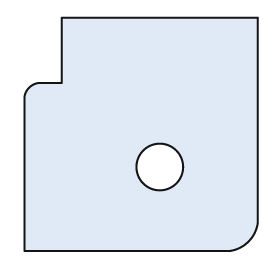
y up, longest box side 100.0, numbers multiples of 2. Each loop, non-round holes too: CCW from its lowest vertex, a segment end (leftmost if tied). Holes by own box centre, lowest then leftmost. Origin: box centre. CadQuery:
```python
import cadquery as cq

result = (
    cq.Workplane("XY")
    .moveTo(-50.0, -50.0)
    .lineTo(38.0, -50.0)
    .threePointArc((46.0, -46.0), (50.0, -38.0))
    .lineTo(50.0, 50.0)
    .lineTo(-34.0, 50.0)
    .lineTo(-34.0, 22.0)
    .lineTo(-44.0, 22.0)
    .threePointArc((-48.0, 20.0), (-50.0, 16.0))
    .close()
    .moveTo(8.0, -14.0)
    .circle(10.0)
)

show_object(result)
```